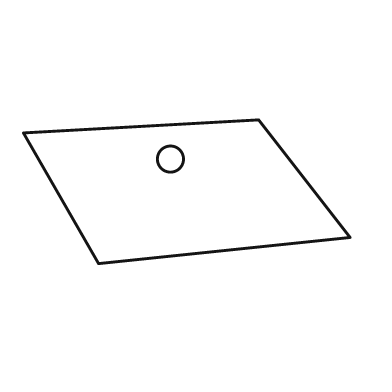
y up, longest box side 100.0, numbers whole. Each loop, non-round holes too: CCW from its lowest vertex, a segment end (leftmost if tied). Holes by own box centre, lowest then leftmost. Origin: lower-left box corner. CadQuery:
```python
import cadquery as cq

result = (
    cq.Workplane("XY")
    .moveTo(23.0, 0.0)
    .lineTo(100.0, 8.0)
    .lineTo(72.0, 44.0)
    .lineTo(0.0, 40.0)
    .close()
    .moveTo(45.0, 32.0)
    .circle(4.0)
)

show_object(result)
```